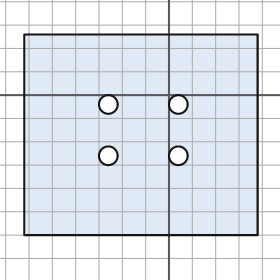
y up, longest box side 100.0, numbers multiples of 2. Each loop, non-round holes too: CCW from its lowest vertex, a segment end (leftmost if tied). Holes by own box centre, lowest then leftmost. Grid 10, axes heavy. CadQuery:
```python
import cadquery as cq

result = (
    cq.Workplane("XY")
    .moveTo(-62.0, -60.0)
    .lineTo(38.0, -60.0)
    .lineTo(38.0, 26.0)
    .lineTo(-62.0, 26.0)
    .close()
    .moveTo(-26.0, -26.0)
    .circle(4.0)
    .moveTo(4.0, -26.0)
    .circle(4.0)
    .moveTo(-26.0, -4.0)
    .circle(4.0)
    .moveTo(4.0, -4.0)
    .circle(4.0)
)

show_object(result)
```